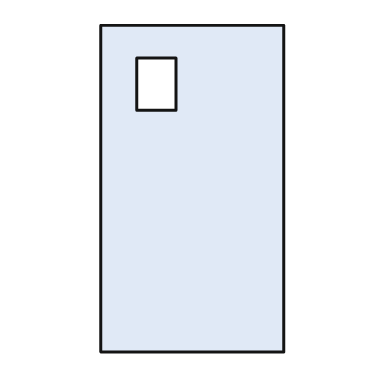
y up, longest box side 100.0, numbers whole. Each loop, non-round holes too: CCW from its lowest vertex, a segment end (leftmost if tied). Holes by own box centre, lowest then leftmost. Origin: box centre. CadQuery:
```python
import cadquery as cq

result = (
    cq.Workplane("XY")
    .moveTo(-28.0, -50.0)
    .lineTo(28.0, -50.0)
    .lineTo(28.0, 50.0)
    .lineTo(-28.0, 50.0)
    .close()
    .moveTo(-17.0, 24.0)
    .lineTo(-5.0, 24.0)
    .lineTo(-5.0, 40.0)
    .lineTo(-17.0, 40.0)
    .close()
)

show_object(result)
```